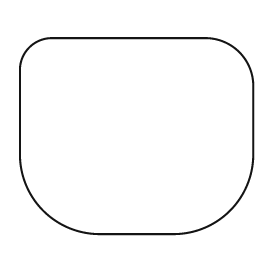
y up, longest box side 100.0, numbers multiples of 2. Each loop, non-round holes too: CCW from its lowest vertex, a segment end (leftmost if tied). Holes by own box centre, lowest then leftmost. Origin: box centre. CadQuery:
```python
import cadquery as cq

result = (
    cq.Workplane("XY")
    .moveTo(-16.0, -42.0)
    .lineTo(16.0, -42.0)
    .threePointArc((40.0, -32.0), (50.0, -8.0))
    .lineTo(50.0, 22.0)
    .threePointArc((44.0, 36.0), (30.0, 42.0))
    .lineTo(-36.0, 42.0)
    .threePointArc((-46.0, 38.0), (-50.0, 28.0))
    .lineTo(-50.0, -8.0)
    .threePointArc((-40.0, -32.0), (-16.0, -42.0))
    .close()
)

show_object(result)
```